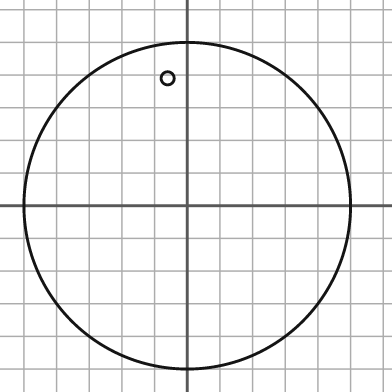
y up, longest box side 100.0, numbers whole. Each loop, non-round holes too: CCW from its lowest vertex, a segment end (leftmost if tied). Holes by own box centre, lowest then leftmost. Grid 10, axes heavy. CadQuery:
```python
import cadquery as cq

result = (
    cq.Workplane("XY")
    .moveTo(0.0, 0.0)
    .circle(50.0)
    .moveTo(-6.0, 39.0)
    .circle(2.0)
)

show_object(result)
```